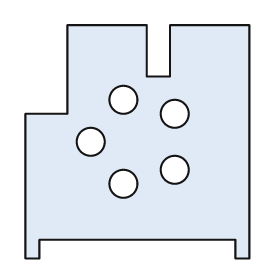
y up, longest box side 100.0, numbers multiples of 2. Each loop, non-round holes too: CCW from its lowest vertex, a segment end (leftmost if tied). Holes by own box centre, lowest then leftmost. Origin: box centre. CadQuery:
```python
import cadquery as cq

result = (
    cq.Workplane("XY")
    .moveTo(-48.0, -50.0)
    .lineTo(-42.0, -50.0)
    .lineTo(-42.0, -42.0)
    .lineTo(42.0, -42.0)
    .lineTo(42.0, -50.0)
    .lineTo(48.0, -50.0)
    .lineTo(48.0, 50.0)
    .lineTo(14.0, 50.0)
    .lineTo(14.0, 28.0)
    .lineTo(4.0, 28.0)
    .lineTo(4.0, 50.0)
    .lineTo(-30.0, 50.0)
    .lineTo(-30.0, 12.0)
    .lineTo(-48.0, 12.0)
    .close()
    .moveTo(-6.0, -18.0)
    .circle(6.0)
    .moveTo(16.0, -12.0)
    .circle(6.0)
    .moveTo(-20.0, 0.0)
    .circle(6.0)
    .moveTo(16.0, 12.0)
    .circle(6.0)
    .moveTo(-6.0, 18.0)
    .circle(6.0)
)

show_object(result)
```